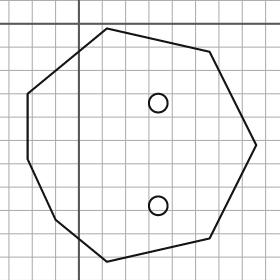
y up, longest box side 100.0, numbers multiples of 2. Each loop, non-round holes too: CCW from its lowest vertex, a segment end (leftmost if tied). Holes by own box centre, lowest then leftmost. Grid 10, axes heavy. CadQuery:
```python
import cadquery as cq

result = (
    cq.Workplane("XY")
    .moveTo(12.0, -102.0)
    .lineTo(56.0, -92.0)
    .lineTo(76.0, -52.0)
    .lineTo(56.0, -12.0)
    .lineTo(12.0, -2.0)
    .lineTo(-22.0, -30.0)
    .lineTo(-22.0, -58.0)
    .lineTo(-10.0, -84.0)
    .close()
    .moveTo(34.0, -78.0)
    .circle(4.0)
    .moveTo(34.0, -34.0)
    .circle(4.0)
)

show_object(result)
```